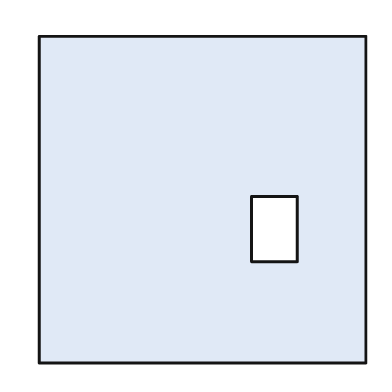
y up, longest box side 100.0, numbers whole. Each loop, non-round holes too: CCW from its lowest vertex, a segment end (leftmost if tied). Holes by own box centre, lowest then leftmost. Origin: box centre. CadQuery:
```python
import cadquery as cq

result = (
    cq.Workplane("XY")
    .moveTo(-50.0, -50.0)
    .lineTo(50.0, -50.0)
    .lineTo(50.0, 50.0)
    .lineTo(-50.0, 50.0)
    .close()
    .moveTo(15.0, -19.0)
    .lineTo(29.0, -19.0)
    .lineTo(29.0, 1.0)
    .lineTo(15.0, 1.0)
    .close()
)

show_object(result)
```